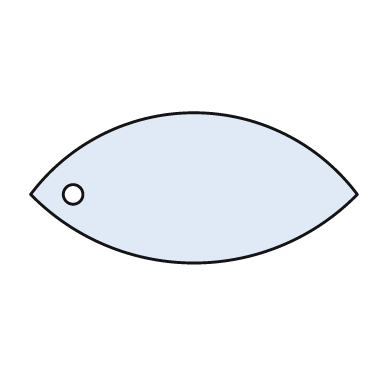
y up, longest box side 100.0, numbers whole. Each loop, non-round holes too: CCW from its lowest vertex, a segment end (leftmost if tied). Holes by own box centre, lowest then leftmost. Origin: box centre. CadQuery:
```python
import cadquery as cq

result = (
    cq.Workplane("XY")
    .moveTo(-50.0, -2.0)
    .threePointArc((0.0, -23.0), (50.0, -2.0))
    .threePointArc((0.0, 23.0), (-50.0, -2.0))
    .close()
    .moveTo(-37.0, -2.0)
    .circle(3.0)
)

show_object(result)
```